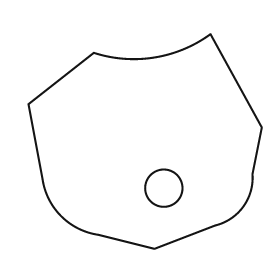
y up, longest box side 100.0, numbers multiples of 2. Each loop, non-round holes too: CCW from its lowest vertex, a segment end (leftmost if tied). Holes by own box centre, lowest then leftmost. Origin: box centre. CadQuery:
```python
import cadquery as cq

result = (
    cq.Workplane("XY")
    .moveTo(4.0, -46.0)
    .lineTo(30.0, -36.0)
    .threePointArc((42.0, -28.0), (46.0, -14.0))
    .lineTo(50.0, 6.0)
    .lineTo(28.0, 46.0)
    .threePointArc((4.0, 36.0), (-22.0, 38.0))
    .lineTo(-50.0, 16.0)
    .lineTo(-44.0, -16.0)
    .threePointArc((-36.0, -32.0), (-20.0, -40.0))
    .close()
    .moveTo(8.0, -20.0)
    .circle(8.0)
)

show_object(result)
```